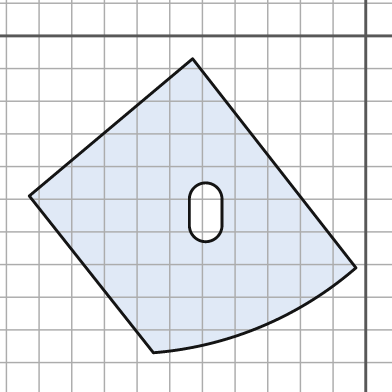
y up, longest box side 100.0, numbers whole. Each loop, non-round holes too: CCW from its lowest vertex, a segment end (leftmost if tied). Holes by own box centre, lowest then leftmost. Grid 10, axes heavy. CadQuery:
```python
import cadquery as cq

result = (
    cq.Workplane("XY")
    .moveTo(-65.0, -97.0)
    .threePointArc((-32.0, -89.0), (-3.0, -71.0))
    .lineTo(-53.0, -7.0)
    .lineTo(-103.0, -49.0)
    .close()
    .moveTo(-54.0, -58.0)
    .threePointArc((-49.0, -63.0), (-44.0, -58.0))
    .lineTo(-44.0, -50.0)
    .threePointArc((-49.0, -45.0), (-54.0, -50.0))
    .close()
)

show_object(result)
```